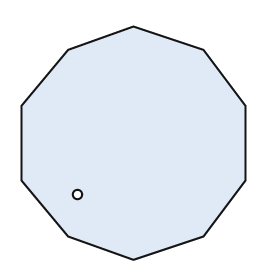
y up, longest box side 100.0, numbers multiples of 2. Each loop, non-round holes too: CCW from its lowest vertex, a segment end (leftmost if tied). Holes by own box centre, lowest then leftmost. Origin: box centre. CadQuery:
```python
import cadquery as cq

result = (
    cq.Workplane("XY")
    .moveTo(0.0, -50.0)
    .lineTo(30.0, -40.0)
    .lineTo(48.0, -16.0)
    .lineTo(48.0, 16.0)
    .lineTo(30.0, 40.0)
    .lineTo(0.0, 50.0)
    .lineTo(-28.0, 40.0)
    .lineTo(-48.0, 16.0)
    .lineTo(-48.0, -16.0)
    .lineTo(-28.0, -40.0)
    .close()
    .moveTo(-24.0, -22.0)
    .circle(2.0)
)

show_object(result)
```